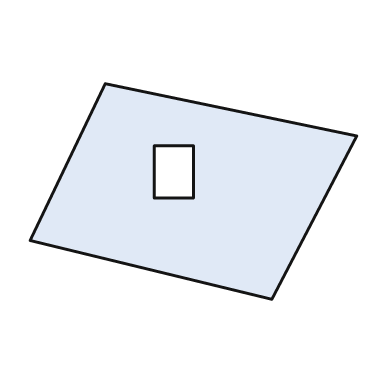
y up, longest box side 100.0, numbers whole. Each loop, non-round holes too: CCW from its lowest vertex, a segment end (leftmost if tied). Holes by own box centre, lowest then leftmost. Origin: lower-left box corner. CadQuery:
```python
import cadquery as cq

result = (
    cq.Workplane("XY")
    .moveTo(74.0, 0.0)
    .lineTo(100.0, 50.0)
    .lineTo(23.0, 66.0)
    .lineTo(0.0, 18.0)
    .close()
    .moveTo(38.0, 31.0)
    .lineTo(50.0, 31.0)
    .lineTo(50.0, 47.0)
    .lineTo(38.0, 47.0)
    .close()
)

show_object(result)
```